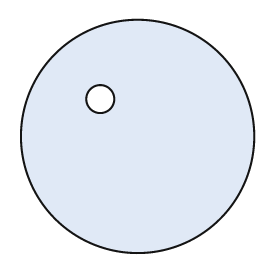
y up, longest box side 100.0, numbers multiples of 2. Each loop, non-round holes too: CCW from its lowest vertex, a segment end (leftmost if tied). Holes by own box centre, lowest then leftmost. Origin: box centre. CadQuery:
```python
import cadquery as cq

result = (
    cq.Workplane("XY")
    .moveTo(0.0, 0.0)
    .circle(50.0)
    .moveTo(-16.0, 16.0)
    .circle(6.0)
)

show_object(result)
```